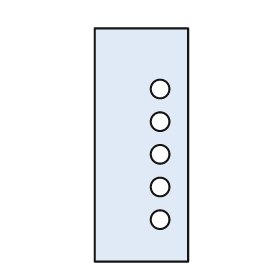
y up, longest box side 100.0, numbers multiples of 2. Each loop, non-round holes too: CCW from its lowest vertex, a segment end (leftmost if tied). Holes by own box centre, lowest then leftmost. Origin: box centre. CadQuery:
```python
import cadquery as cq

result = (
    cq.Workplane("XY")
    .moveTo(-20.0, -50.0)
    .lineTo(20.0, -50.0)
    .lineTo(20.0, 50.0)
    .lineTo(-20.0, 50.0)
    .close()
    .moveTo(8.0, -32.0)
    .circle(4.0)
    .moveTo(8.0, -18.0)
    .circle(4.0)
    .moveTo(8.0, -4.0)
    .circle(4.0)
    .moveTo(8.0, 10.0)
    .circle(4.0)
    .moveTo(8.0, 24.0)
    .circle(4.0)
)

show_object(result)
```